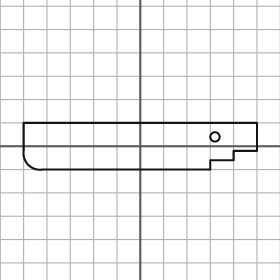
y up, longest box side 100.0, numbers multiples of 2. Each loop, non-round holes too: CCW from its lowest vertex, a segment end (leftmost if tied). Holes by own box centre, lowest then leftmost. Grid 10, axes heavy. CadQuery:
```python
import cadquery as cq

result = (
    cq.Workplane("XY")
    .moveTo(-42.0, -10.0)
    .lineTo(30.0, -10.0)
    .lineTo(30.0, -6.0)
    .lineTo(40.0, -6.0)
    .lineTo(40.0, -2.0)
    .lineTo(50.0, -2.0)
    .lineTo(50.0, 10.0)
    .lineTo(-50.0, 10.0)
    .lineTo(-50.0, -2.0)
    .threePointArc((-48.0, -8.0), (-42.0, -10.0))
    .close()
    .moveTo(32.0, 4.0)
    .circle(2.0)
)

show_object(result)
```